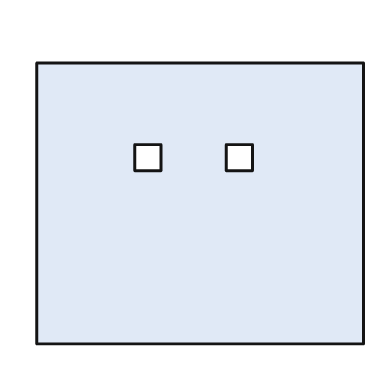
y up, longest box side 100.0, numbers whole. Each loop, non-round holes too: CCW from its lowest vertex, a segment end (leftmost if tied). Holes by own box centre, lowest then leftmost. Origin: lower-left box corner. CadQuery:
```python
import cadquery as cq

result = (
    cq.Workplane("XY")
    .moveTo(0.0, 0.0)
    .lineTo(100.0, 0.0)
    .lineTo(100.0, 86.0)
    .lineTo(0.0, 86.0)
    .close()
    .moveTo(30.0, 53.0)
    .lineTo(38.0, 53.0)
    .lineTo(38.0, 61.0)
    .lineTo(30.0, 61.0)
    .close()
    .moveTo(58.0, 53.0)
    .lineTo(66.0, 53.0)
    .lineTo(66.0, 61.0)
    .lineTo(58.0, 61.0)
    .close()
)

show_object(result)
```